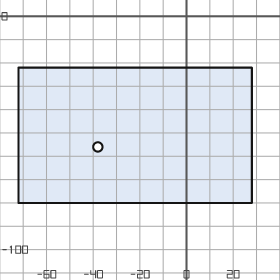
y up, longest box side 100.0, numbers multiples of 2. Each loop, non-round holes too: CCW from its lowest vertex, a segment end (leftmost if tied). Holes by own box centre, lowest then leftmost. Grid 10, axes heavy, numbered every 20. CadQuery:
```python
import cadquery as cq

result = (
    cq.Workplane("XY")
    .moveTo(-72.0, -80.0)
    .lineTo(28.0, -80.0)
    .lineTo(28.0, -22.0)
    .lineTo(-72.0, -22.0)
    .close()
    .moveTo(-38.0, -56.0)
    .circle(2.0)
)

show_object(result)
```